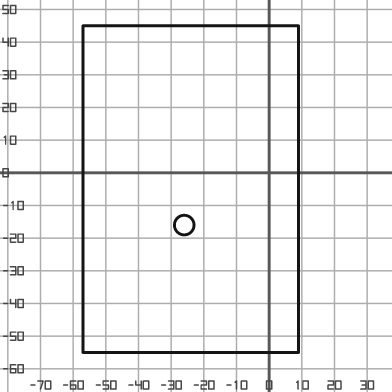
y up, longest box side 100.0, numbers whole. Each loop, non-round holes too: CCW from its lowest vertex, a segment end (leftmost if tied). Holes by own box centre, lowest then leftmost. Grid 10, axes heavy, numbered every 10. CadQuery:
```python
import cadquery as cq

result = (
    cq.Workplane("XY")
    .moveTo(-57.0, -55.0)
    .lineTo(9.0, -55.0)
    .lineTo(9.0, 45.0)
    .lineTo(-57.0, 45.0)
    .close()
    .moveTo(-26.0, -16.0)
    .circle(3.0)
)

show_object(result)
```